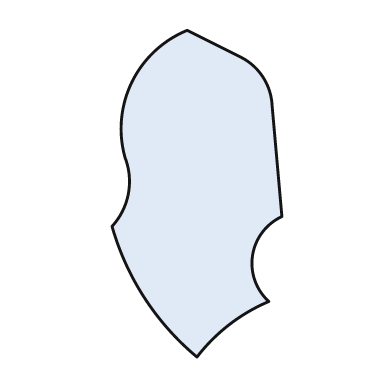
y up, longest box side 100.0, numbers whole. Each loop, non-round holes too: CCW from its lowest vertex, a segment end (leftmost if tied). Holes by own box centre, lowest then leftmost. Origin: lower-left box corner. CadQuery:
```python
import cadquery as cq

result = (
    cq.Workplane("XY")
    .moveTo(26.0, 0.0)
    .threePointArc((36.0, 10.0), (48.0, 17.0))
    .threePointArc((43.0, 31.0), (52.0, 43.0))
    .lineTo(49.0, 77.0)
    .threePointArc((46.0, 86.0), (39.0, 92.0))
    .lineTo(23.0, 100.0)
    .threePointArc((6.0, 84.0), (4.0, 61.0))
    .threePointArc((5.0, 50.0), (0.0, 40.0))
    .threePointArc((10.0, 18.0), (26.0, 0.0))
    .close()
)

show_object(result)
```